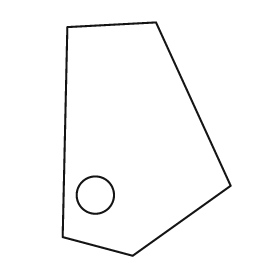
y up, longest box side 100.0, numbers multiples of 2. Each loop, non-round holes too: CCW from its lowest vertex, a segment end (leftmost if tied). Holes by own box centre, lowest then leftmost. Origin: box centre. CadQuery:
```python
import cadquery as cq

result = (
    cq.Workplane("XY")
    .moveTo(-6.0, -50.0)
    .lineTo(36.0, -20.0)
    .lineTo(4.0, 50.0)
    .lineTo(-34.0, 48.0)
    .lineTo(-36.0, -42.0)
    .close()
    .moveTo(-22.0, -24.0)
    .circle(8.0)
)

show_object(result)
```